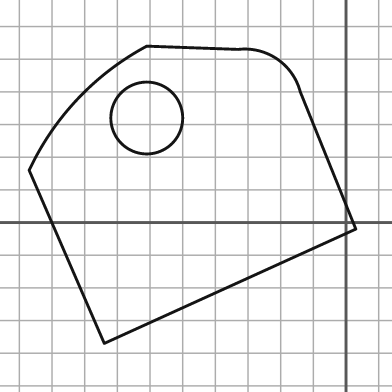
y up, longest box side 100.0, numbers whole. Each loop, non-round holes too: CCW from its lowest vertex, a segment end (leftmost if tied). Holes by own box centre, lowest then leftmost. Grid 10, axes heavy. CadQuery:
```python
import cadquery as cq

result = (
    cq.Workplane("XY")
    .moveTo(-74.0, -37.0)
    .lineTo(3.0, -2.0)
    .lineTo(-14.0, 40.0)
    .threePointArc((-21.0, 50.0), (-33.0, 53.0))
    .lineTo(-61.0, 54.0)
    .threePointArc((-82.0, 38.0), (-97.0, 16.0))
    .close()
    .moveTo(-61.0, 32.0)
    .circle(11.0)
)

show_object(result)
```